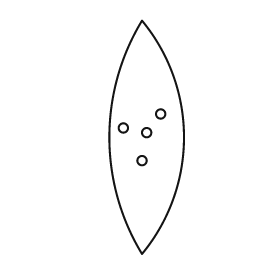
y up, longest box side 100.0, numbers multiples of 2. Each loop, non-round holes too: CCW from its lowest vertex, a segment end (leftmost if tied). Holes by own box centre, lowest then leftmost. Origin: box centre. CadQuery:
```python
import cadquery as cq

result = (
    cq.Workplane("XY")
    .moveTo(-2.0, -50.0)
    .threePointArc((16.0, 0.0), (-2.0, 50.0))
    .threePointArc((-16.0, 0.0), (-2.0, -50.0))
    .close()
    .moveTo(-2.0, -10.0)
    .circle(2.0)
    .moveTo(0.0, 2.0)
    .circle(2.0)
    .moveTo(-10.0, 4.0)
    .circle(2.0)
    .moveTo(6.0, 10.0)
    .circle(2.0)
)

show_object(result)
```